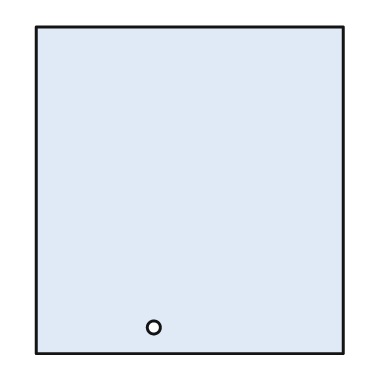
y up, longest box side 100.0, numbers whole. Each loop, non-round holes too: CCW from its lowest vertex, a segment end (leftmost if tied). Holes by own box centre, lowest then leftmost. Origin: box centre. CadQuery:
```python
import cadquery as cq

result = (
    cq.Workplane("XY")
    .moveTo(-47.0, -50.0)
    .lineTo(47.0, -50.0)
    .lineTo(47.0, 50.0)
    .lineTo(-47.0, 50.0)
    .close()
    .moveTo(-11.0, -42.0)
    .circle(2.0)
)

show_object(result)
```